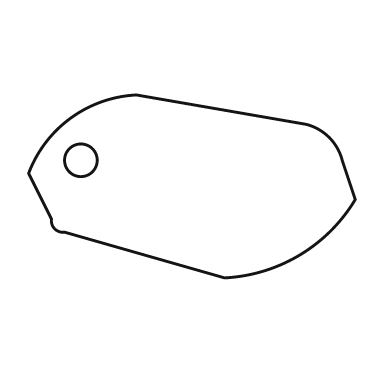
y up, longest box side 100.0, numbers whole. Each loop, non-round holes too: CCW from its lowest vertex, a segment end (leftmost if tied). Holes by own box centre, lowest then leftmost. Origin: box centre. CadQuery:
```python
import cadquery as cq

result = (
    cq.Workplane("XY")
    .moveTo(10.0, -28.0)
    .threePointArc((33.0, -21.0), (50.0, -4.0))
    .lineTo(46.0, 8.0)
    .threePointArc((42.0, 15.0), (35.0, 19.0))
    .lineTo(-17.0, 28.0)
    .threePointArc((-37.0, 21.0), (-50.0, 4.0))
    .lineTo(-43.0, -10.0)
    .threePointArc((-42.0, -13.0), (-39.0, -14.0))
    .close()
    .moveTo(-34.0, 8.0)
    .circle(5.0)
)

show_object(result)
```